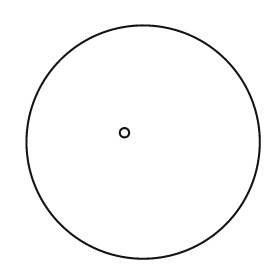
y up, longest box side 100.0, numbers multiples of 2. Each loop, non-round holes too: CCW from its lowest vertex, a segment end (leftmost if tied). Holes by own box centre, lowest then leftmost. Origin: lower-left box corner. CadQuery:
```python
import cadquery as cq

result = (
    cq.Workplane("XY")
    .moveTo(50.0, 50.0)
    .circle(50.0)
    .moveTo(42.0, 54.0)
    .circle(2.0)
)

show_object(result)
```